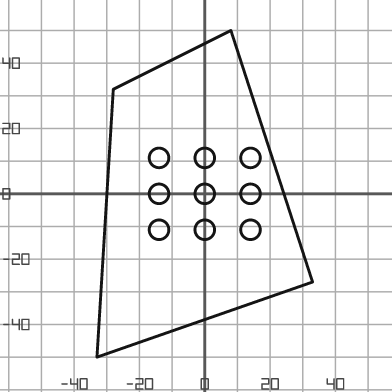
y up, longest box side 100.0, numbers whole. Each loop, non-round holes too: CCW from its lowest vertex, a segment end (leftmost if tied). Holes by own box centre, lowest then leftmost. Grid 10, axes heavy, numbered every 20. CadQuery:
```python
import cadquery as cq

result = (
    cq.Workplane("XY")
    .moveTo(-33.0, -50.0)
    .lineTo(33.0, -27.0)
    .lineTo(8.0, 50.0)
    .lineTo(-28.0, 32.0)
    .close()
    .moveTo(-14.0, -11.0)
    .circle(3.0)
    .moveTo(0.0, -11.0)
    .circle(3.0)
    .moveTo(14.0, -11.0)
    .circle(3.0)
    .moveTo(-14.0, 0.0)
    .circle(3.0)
    .moveTo(0.0, 0.0)
    .circle(3.0)
    .moveTo(14.0, 0.0)
    .circle(3.0)
    .moveTo(-14.0, 11.0)
    .circle(3.0)
    .moveTo(0.0, 11.0)
    .circle(3.0)
    .moveTo(14.0, 11.0)
    .circle(3.0)
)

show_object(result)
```